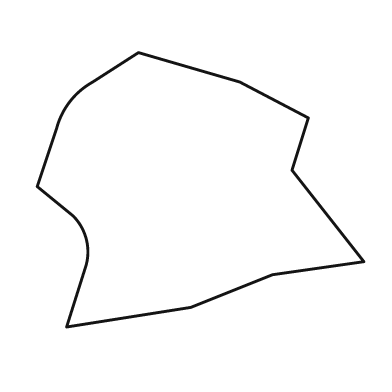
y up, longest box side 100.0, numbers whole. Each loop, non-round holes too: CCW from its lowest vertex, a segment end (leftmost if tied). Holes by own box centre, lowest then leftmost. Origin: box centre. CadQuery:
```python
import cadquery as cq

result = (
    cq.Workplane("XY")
    .moveTo(-41.0, -42.0)
    .lineTo(-3.0, -36.0)
    .lineTo(22.0, -26.0)
    .lineTo(50.0, -22.0)
    .lineTo(28.0, 6.0)
    .lineTo(33.0, 22.0)
    .lineTo(12.0, 33.0)
    .lineTo(-19.0, 42.0)
    .lineTo(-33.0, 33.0)
    .threePointArc((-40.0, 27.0), (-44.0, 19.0))
    .lineTo(-50.0, 1.0)
    .lineTo(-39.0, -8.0)
    .threePointArc((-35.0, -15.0), (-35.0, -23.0))
    .close()
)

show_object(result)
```